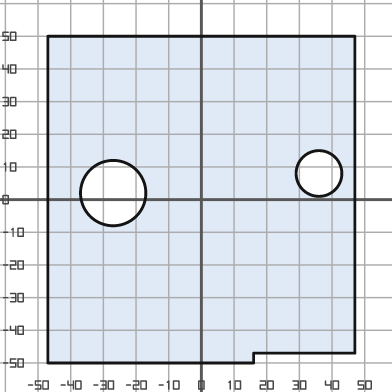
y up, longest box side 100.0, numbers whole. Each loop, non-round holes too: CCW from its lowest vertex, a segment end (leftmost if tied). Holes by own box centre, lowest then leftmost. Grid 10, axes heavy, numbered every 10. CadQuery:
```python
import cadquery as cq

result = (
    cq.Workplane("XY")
    .moveTo(-47.0, -50.0)
    .lineTo(16.0, -50.0)
    .lineTo(16.0, -47.0)
    .lineTo(47.0, -47.0)
    .lineTo(47.0, 50.0)
    .lineTo(-47.0, 50.0)
    .close()
    .moveTo(-27.0, 2.0)
    .circle(10.0)
    .moveTo(36.0, 8.0)
    .circle(7.0)
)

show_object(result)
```